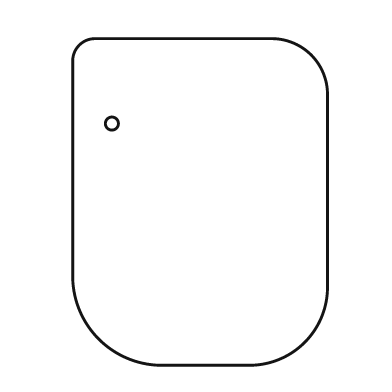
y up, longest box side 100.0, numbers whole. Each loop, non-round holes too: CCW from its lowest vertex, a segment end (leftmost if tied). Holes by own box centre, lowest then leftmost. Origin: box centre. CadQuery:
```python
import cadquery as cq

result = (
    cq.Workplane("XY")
    .moveTo(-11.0, -50.0)
    .lineTo(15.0, -50.0)
    .threePointArc((32.0, -43.0), (39.0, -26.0))
    .lineTo(39.0, 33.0)
    .threePointArc((34.0, 45.0), (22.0, 50.0))
    .lineTo(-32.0, 50.0)
    .threePointArc((-37.0, 48.0), (-39.0, 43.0))
    .lineTo(-39.0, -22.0)
    .threePointArc((-31.0, -42.0), (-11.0, -50.0))
    .close()
    .moveTo(-27.0, 24.0)
    .circle(2.0)
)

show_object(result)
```